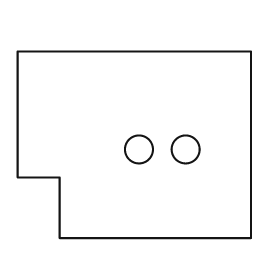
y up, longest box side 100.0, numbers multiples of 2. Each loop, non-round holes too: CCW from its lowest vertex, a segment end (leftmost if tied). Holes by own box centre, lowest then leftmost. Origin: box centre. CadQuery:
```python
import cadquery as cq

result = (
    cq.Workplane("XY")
    .moveTo(-32.0, -40.0)
    .lineTo(50.0, -40.0)
    .lineTo(50.0, 40.0)
    .lineTo(-50.0, 40.0)
    .lineTo(-50.0, -14.0)
    .lineTo(-32.0, -14.0)
    .close()
    .moveTo(2.0, -2.0)
    .circle(6.0)
    .moveTo(22.0, -2.0)
    .circle(6.0)
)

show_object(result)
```